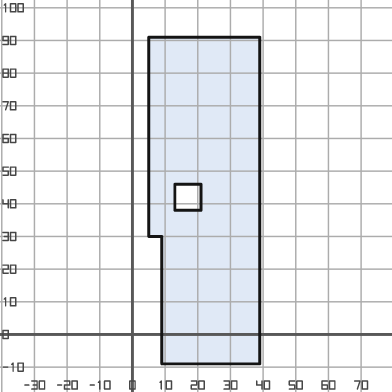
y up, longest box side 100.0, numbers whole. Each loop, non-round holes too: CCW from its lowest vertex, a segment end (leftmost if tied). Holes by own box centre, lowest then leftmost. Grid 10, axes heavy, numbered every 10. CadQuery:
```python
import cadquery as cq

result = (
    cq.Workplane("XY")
    .moveTo(9.0, -9.0)
    .lineTo(39.0, -9.0)
    .lineTo(39.0, 91.0)
    .lineTo(5.0, 91.0)
    .lineTo(5.0, 30.0)
    .lineTo(9.0, 30.0)
    .close()
    .moveTo(13.0, 38.0)
    .lineTo(21.0, 38.0)
    .lineTo(21.0, 46.0)
    .lineTo(13.0, 46.0)
    .close()
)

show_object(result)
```